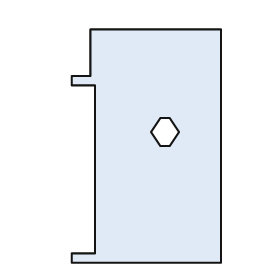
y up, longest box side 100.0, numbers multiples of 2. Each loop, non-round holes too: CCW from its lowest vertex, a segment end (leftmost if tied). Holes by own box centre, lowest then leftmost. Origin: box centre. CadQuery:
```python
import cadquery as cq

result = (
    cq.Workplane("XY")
    .moveTo(-32.0, -50.0)
    .lineTo(32.0, -50.0)
    .lineTo(32.0, 50.0)
    .lineTo(-24.0, 50.0)
    .lineTo(-24.0, 30.0)
    .lineTo(-32.0, 30.0)
    .lineTo(-32.0, 26.0)
    .lineTo(-22.0, 26.0)
    .lineTo(-22.0, -46.0)
    .lineTo(-32.0, -46.0)
    .close()
    .moveTo(6.0, 0.0)
    .lineTo(10.0, 0.0)
    .lineTo(14.0, 6.0)
    .lineTo(10.0, 12.0)
    .lineTo(6.0, 12.0)
    .lineTo(2.0, 6.0)
    .close()
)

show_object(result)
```